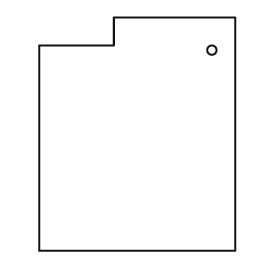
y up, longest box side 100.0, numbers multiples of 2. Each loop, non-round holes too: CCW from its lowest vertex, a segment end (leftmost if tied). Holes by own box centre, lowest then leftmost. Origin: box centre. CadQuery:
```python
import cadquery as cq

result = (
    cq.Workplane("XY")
    .moveTo(-42.0, -50.0)
    .lineTo(42.0, -50.0)
    .lineTo(42.0, 50.0)
    .lineTo(-10.0, 50.0)
    .lineTo(-10.0, 38.0)
    .lineTo(-42.0, 38.0)
    .close()
    .moveTo(32.0, 36.0)
    .circle(2.0)
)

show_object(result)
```